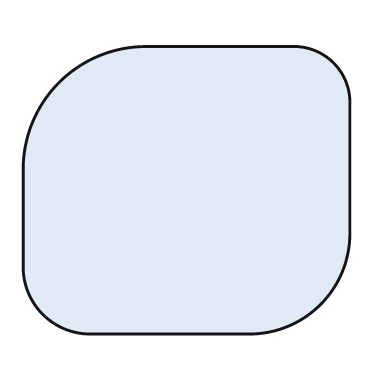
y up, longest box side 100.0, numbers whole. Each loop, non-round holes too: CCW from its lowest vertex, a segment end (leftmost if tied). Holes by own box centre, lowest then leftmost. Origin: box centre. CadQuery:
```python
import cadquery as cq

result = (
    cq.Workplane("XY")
    .moveTo(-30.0, -44.0)
    .lineTo(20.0, -44.0)
    .threePointArc((41.0, -35.0), (50.0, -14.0))
    .lineTo(50.0, 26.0)
    .threePointArc((45.0, 39.0), (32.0, 44.0))
    .lineTo(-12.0, 44.0)
    .threePointArc((-39.0, 33.0), (-50.0, 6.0))
    .lineTo(-50.0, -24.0)
    .threePointArc((-44.0, -38.0), (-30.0, -44.0))
    .close()
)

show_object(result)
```